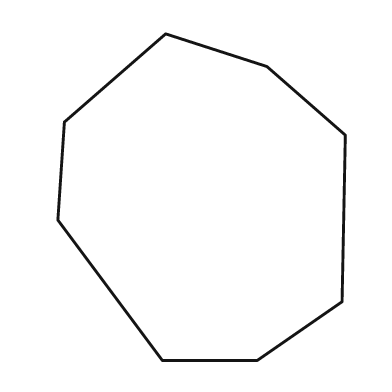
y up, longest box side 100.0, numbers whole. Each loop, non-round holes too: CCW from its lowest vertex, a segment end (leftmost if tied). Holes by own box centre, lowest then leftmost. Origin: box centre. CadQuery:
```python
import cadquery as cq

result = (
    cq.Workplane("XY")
    .moveTo(-12.0, -50.0)
    .lineTo(17.0, -50.0)
    .lineTo(43.0, -32.0)
    .lineTo(44.0, 19.0)
    .lineTo(20.0, 40.0)
    .lineTo(-11.0, 50.0)
    .lineTo(-42.0, 23.0)
    .lineTo(-44.0, -7.0)
    .close()
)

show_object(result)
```